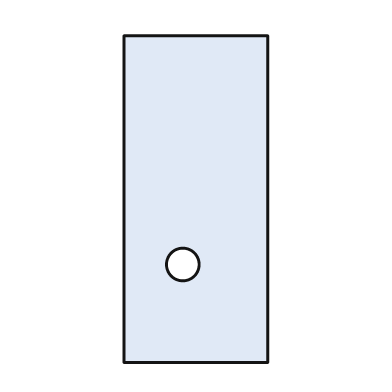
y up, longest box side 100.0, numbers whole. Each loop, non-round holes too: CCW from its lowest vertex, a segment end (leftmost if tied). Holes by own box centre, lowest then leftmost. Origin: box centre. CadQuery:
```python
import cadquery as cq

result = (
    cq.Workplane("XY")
    .moveTo(-22.0, -50.0)
    .lineTo(22.0, -50.0)
    .lineTo(22.0, 50.0)
    .lineTo(-22.0, 50.0)
    .close()
    .moveTo(-4.0, -20.0)
    .circle(5.0)
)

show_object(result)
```